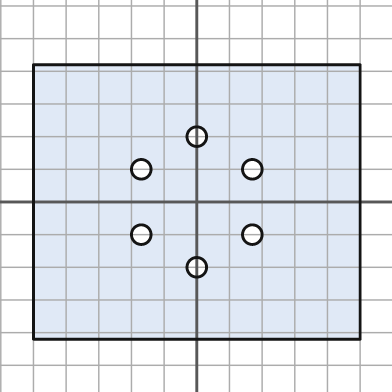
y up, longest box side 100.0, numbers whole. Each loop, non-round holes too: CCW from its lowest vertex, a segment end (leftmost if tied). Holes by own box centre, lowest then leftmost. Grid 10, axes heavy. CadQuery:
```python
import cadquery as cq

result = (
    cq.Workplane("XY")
    .moveTo(-50.0, -42.0)
    .lineTo(50.0, -42.0)
    .lineTo(50.0, 42.0)
    .lineTo(-50.0, 42.0)
    .close()
    .moveTo(0.0, -20.0)
    .circle(3.0)
    .moveTo(-17.0, -10.0)
    .circle(3.0)
    .moveTo(17.0, -10.0)
    .circle(3.0)
    .moveTo(-17.0, 10.0)
    .circle(3.0)
    .moveTo(17.0, 10.0)
    .circle(3.0)
    .moveTo(0.0, 20.0)
    .circle(3.0)
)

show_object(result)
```